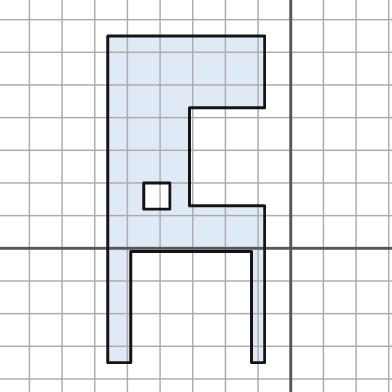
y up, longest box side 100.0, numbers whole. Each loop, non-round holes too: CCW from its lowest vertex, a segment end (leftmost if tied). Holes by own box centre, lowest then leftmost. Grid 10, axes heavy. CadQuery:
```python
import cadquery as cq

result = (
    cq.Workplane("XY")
    .moveTo(-56.0, -35.0)
    .lineTo(-49.0, -35.0)
    .lineTo(-49.0, -1.0)
    .lineTo(-12.0, -1.0)
    .lineTo(-12.0, -35.0)
    .lineTo(-8.0, -35.0)
    .lineTo(-8.0, 13.0)
    .lineTo(-31.0, 13.0)
    .lineTo(-31.0, 43.0)
    .lineTo(-8.0, 43.0)
    .lineTo(-8.0, 65.0)
    .lineTo(-56.0, 65.0)
    .close()
    .moveTo(-45.0, 12.0)
    .lineTo(-37.0, 12.0)
    .lineTo(-37.0, 20.0)
    .lineTo(-45.0, 20.0)
    .close()
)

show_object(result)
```